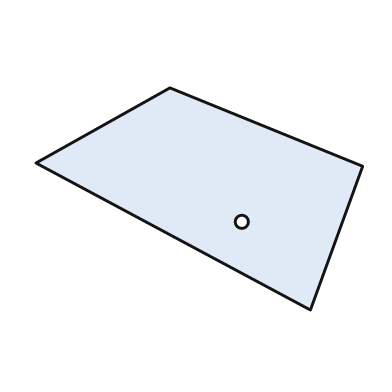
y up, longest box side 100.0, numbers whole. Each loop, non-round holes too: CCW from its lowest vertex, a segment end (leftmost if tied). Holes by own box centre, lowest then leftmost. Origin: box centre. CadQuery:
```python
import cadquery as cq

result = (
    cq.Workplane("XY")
    .moveTo(34.0, -34.0)
    .lineTo(50.0, 10.0)
    .lineTo(-9.0, 34.0)
    .lineTo(-50.0, 11.0)
    .close()
    .moveTo(13.0, -7.0)
    .circle(2.0)
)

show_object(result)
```